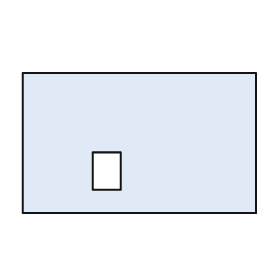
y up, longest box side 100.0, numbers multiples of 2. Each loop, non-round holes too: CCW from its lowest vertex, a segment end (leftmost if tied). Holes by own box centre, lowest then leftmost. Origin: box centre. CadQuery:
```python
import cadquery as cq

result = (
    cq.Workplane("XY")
    .moveTo(-50.0, -30.0)
    .lineTo(50.0, -30.0)
    .lineTo(50.0, 30.0)
    .lineTo(-50.0, 30.0)
    .close()
    .moveTo(-20.0, -20.0)
    .lineTo(-8.0, -20.0)
    .lineTo(-8.0, -4.0)
    .lineTo(-20.0, -4.0)
    .close()
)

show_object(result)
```